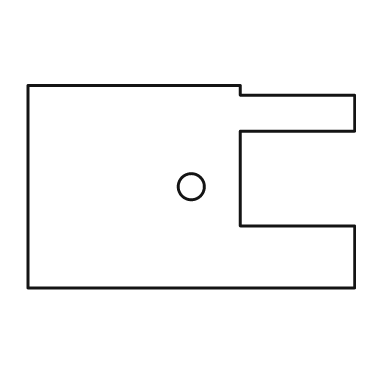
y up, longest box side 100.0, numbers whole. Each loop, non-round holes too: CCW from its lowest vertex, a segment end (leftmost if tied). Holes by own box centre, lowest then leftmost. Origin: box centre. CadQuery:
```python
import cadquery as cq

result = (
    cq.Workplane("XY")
    .moveTo(-50.0, -31.0)
    .lineTo(50.0, -31.0)
    .lineTo(50.0, -12.0)
    .lineTo(15.0, -12.0)
    .lineTo(15.0, 17.0)
    .lineTo(50.0, 17.0)
    .lineTo(50.0, 28.0)
    .lineTo(15.0, 28.0)
    .lineTo(15.0, 31.0)
    .lineTo(-50.0, 31.0)
    .close()
    .moveTo(0.0, 0.0)
    .circle(4.0)
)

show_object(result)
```